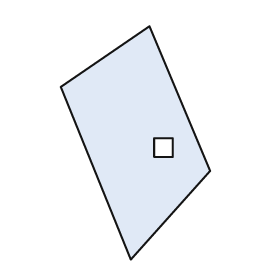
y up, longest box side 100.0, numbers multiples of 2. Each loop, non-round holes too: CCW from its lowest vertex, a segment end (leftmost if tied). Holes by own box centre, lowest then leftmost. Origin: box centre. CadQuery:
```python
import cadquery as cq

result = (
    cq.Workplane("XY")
    .moveTo(-2.0, -50.0)
    .lineTo(32.0, -12.0)
    .lineTo(6.0, 50.0)
    .lineTo(-32.0, 24.0)
    .close()
    .moveTo(8.0, -6.0)
    .lineTo(16.0, -6.0)
    .lineTo(16.0, 2.0)
    .lineTo(8.0, 2.0)
    .close()
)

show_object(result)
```